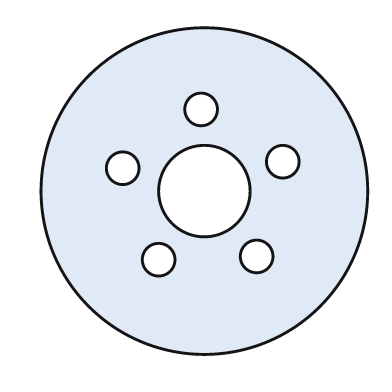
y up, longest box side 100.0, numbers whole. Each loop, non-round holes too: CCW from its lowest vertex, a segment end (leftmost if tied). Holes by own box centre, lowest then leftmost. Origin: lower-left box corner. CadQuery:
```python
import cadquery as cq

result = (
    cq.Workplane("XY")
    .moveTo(50.0, 50.0)
    .circle(50.0)
    .moveTo(36.0, 29.0)
    .circle(5.0)
    .moveTo(66.0, 30.0)
    .circle(5.0)
    .moveTo(50.0, 50.0)
    .circle(14.0)
    .moveTo(25.0, 57.0)
    .circle(5.0)
    .moveTo(74.0, 59.0)
    .circle(5.0)
    .moveTo(49.0, 75.0)
    .circle(5.0)
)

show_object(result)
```